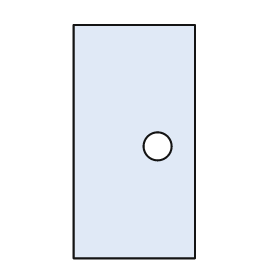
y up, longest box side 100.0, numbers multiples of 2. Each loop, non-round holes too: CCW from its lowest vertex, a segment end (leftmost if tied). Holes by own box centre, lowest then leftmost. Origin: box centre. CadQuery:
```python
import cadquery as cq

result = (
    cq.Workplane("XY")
    .moveTo(-26.0, -50.0)
    .lineTo(26.0, -50.0)
    .lineTo(26.0, 50.0)
    .lineTo(-26.0, 50.0)
    .close()
    .moveTo(10.0, -2.0)
    .circle(6.0)
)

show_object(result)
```